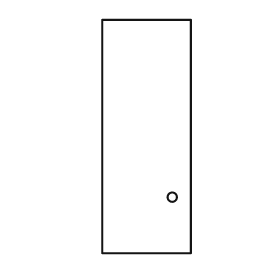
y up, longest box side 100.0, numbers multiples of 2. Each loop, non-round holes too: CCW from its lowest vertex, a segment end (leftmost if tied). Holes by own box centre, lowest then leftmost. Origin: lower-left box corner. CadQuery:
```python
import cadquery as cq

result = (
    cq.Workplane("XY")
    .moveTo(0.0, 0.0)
    .lineTo(38.0, 0.0)
    .lineTo(38.0, 100.0)
    .lineTo(0.0, 100.0)
    .close()
    .moveTo(30.0, 24.0)
    .circle(2.0)
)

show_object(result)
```